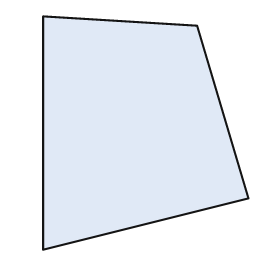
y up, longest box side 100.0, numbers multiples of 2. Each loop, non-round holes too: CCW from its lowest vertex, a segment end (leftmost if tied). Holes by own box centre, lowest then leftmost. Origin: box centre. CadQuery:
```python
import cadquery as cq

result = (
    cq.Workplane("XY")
    .moveTo(-44.0, -50.0)
    .lineTo(44.0, -28.0)
    .lineTo(22.0, 46.0)
    .lineTo(-44.0, 50.0)
    .close()
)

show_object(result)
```